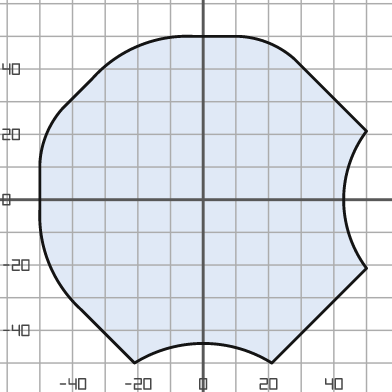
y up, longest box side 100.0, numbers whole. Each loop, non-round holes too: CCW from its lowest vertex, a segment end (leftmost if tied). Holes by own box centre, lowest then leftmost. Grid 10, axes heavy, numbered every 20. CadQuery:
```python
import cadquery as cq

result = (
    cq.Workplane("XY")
    .moveTo(-21.0, -50.0)
    .threePointArc((0.0, -44.0), (21.0, -50.0))
    .lineTo(50.0, -21.0)
    .threePointArc((43.0, 0.0), (50.0, 21.0))
    .lineTo(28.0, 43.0)
    .threePointArc((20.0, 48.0), (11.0, 50.0))
    .lineTo(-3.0, 50.0)
    .threePointArc((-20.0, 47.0), (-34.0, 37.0))
    .lineTo(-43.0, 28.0)
    .threePointArc((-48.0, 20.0), (-50.0, 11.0))
    .lineTo(-50.0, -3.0)
    .threePointArc((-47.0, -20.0), (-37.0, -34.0))
    .close()
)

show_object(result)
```